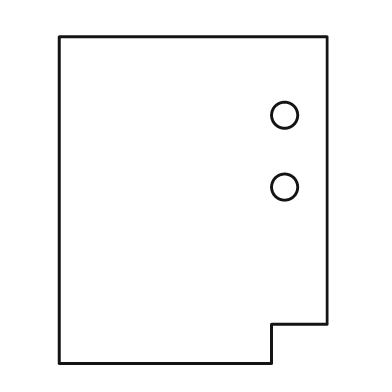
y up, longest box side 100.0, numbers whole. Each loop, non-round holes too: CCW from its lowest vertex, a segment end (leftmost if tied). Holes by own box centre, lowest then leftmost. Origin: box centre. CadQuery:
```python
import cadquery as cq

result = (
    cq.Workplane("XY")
    .moveTo(-41.0, -50.0)
    .lineTo(24.0, -50.0)
    .lineTo(24.0, -38.0)
    .lineTo(41.0, -38.0)
    .lineTo(41.0, 50.0)
    .lineTo(-41.0, 50.0)
    .close()
    .moveTo(28.0, 4.0)
    .circle(4.0)
    .moveTo(28.0, 26.0)
    .circle(4.0)
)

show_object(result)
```